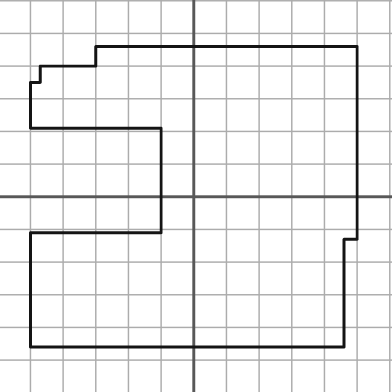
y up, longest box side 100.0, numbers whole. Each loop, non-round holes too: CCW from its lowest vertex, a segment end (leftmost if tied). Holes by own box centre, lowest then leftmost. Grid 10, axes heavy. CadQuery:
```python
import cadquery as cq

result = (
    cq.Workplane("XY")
    .moveTo(-50.0, -46.0)
    .lineTo(46.0, -46.0)
    .lineTo(46.0, -13.0)
    .lineTo(50.0, -13.0)
    .lineTo(50.0, 46.0)
    .lineTo(-30.0, 46.0)
    .lineTo(-30.0, 40.0)
    .lineTo(-47.0, 40.0)
    .lineTo(-47.0, 35.0)
    .lineTo(-50.0, 35.0)
    .lineTo(-50.0, 21.0)
    .lineTo(-10.0, 21.0)
    .lineTo(-10.0, -11.0)
    .lineTo(-50.0, -11.0)
    .close()
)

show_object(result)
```